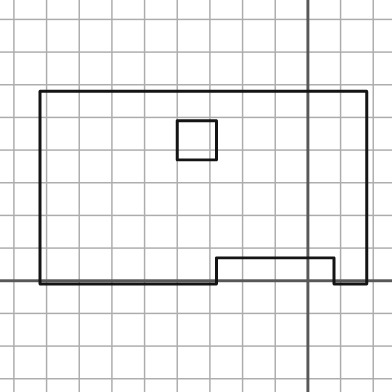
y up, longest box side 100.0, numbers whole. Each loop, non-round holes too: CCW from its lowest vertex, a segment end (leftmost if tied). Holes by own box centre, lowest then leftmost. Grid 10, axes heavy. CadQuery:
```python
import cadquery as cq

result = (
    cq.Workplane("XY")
    .moveTo(-82.0, -1.0)
    .lineTo(-28.0, -1.0)
    .lineTo(-28.0, 7.0)
    .lineTo(8.0, 7.0)
    .lineTo(8.0, -1.0)
    .lineTo(18.0, -1.0)
    .lineTo(18.0, 58.0)
    .lineTo(-82.0, 58.0)
    .close()
    .moveTo(-40.0, 37.0)
    .lineTo(-28.0, 37.0)
    .lineTo(-28.0, 49.0)
    .lineTo(-40.0, 49.0)
    .close()
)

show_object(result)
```